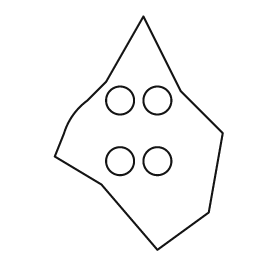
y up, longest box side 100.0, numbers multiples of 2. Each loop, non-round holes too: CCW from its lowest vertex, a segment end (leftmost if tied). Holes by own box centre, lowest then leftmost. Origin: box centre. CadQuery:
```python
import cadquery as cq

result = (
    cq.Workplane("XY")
    .moveTo(8.0, -50.0)
    .lineTo(30.0, -34.0)
    .lineTo(36.0, 0.0)
    .lineTo(18.0, 18.0)
    .lineTo(2.0, 50.0)
    .lineTo(-14.0, 22.0)
    .lineTo(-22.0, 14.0)
    .threePointArc((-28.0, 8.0), (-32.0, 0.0))
    .lineTo(-36.0, -10.0)
    .lineTo(-16.0, -22.0)
    .close()
    .moveTo(-8.0, -12.0)
    .circle(6.0)
    .moveTo(8.0, -12.0)
    .circle(6.0)
    .moveTo(-8.0, 14.0)
    .circle(6.0)
    .moveTo(8.0, 14.0)
    .circle(6.0)
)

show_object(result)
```